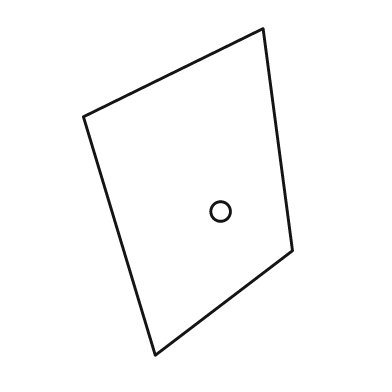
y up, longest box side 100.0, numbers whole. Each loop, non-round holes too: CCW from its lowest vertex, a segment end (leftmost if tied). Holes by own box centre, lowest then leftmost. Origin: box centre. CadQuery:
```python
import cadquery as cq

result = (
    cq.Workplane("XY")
    .moveTo(-10.0, -50.0)
    .lineTo(32.0, -18.0)
    .lineTo(23.0, 50.0)
    .lineTo(-32.0, 23.0)
    .close()
    .moveTo(10.0, -6.0)
    .circle(3.0)
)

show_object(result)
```